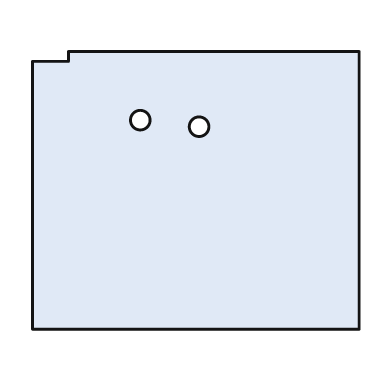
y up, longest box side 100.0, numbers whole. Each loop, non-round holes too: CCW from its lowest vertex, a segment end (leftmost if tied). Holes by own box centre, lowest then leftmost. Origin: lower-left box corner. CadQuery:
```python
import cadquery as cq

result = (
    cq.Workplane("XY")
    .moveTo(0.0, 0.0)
    .lineTo(100.0, 0.0)
    .lineTo(100.0, 85.0)
    .lineTo(11.0, 85.0)
    .lineTo(11.0, 82.0)
    .lineTo(0.0, 82.0)
    .close()
    .moveTo(51.0, 62.0)
    .circle(3.0)
    .moveTo(33.0, 64.0)
    .circle(3.0)
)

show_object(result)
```